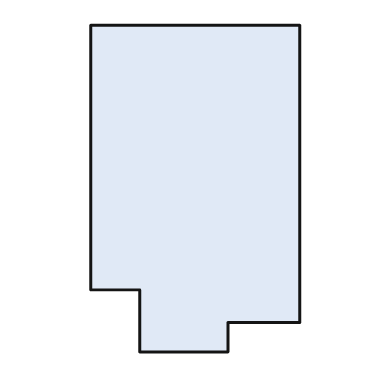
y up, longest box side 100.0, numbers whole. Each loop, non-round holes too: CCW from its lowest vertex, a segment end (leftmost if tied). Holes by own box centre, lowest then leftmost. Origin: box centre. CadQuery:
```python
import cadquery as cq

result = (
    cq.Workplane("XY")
    .moveTo(-17.0, -50.0)
    .lineTo(10.0, -50.0)
    .lineTo(10.0, -41.0)
    .lineTo(32.0, -41.0)
    .lineTo(32.0, 50.0)
    .lineTo(-32.0, 50.0)
    .lineTo(-32.0, -31.0)
    .lineTo(-17.0, -31.0)
    .close()
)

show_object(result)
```